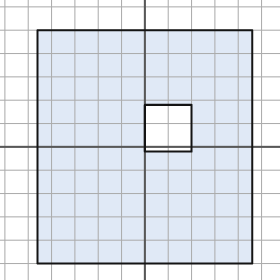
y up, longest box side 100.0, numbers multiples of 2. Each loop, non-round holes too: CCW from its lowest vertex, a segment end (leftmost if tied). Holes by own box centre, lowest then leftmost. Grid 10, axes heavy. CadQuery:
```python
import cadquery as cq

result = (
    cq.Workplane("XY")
    .moveTo(-46.0, -50.0)
    .lineTo(46.0, -50.0)
    .lineTo(46.0, 50.0)
    .lineTo(-46.0, 50.0)
    .close()
    .moveTo(0.0, -2.0)
    .lineTo(20.0, -2.0)
    .lineTo(20.0, 18.0)
    .lineTo(0.0, 18.0)
    .close()
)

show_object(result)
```